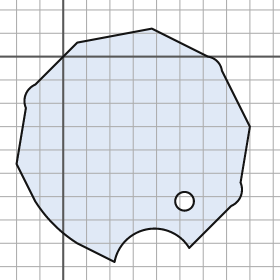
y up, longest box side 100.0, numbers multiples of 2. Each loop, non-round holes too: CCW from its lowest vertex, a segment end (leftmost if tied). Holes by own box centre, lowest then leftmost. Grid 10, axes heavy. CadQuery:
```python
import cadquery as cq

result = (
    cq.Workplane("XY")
    .moveTo(22.0, -88.0)
    .threePointArc((36.0, -74.0), (54.0, -82.0))
    .lineTo(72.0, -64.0)
    .threePointArc((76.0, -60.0), (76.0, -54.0))
    .lineTo(80.0, -30.0)
    .lineTo(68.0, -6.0)
    .threePointArc((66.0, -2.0), (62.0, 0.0))
    .lineTo(38.0, 12.0)
    .lineTo(6.0, 6.0)
    .lineTo(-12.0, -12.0)
    .threePointArc((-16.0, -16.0), (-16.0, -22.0))
    .lineTo(-20.0, -46.0)
    .lineTo(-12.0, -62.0)
    .threePointArc((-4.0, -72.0), (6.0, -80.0))
    .close()
    .moveTo(52.0, -62.0)
    .circle(4.0)
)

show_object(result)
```